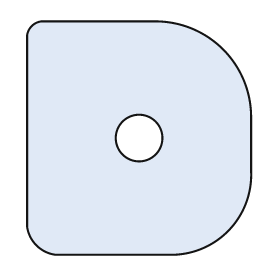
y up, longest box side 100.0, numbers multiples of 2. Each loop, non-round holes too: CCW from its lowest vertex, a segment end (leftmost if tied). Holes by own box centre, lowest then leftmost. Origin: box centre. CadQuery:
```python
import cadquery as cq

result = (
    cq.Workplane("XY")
    .moveTo(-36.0, -50.0)
    .lineTo(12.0, -50.0)
    .threePointArc((38.0, -40.0), (48.0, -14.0))
    .lineTo(48.0, 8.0)
    .threePointArc((36.0, 38.0), (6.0, 50.0))
    .lineTo(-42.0, 50.0)
    .threePointArc((-46.0, 48.0), (-48.0, 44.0))
    .lineTo(-48.0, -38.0)
    .threePointArc((-44.0, -46.0), (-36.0, -50.0))
    .close()
    .moveTo(0.0, 0.0)
    .circle(10.0)
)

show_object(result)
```